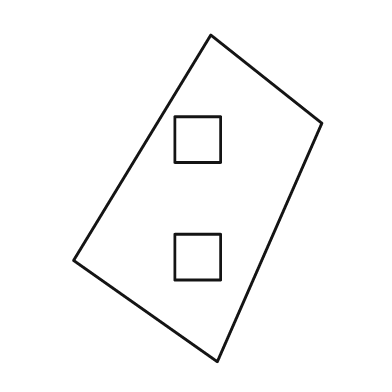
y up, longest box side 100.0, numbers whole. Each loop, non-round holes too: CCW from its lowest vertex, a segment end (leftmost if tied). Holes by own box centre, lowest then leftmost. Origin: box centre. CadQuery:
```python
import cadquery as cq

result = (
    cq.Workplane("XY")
    .moveTo(6.0, -50.0)
    .lineTo(38.0, 23.0)
    .lineTo(4.0, 50.0)
    .lineTo(-38.0, -19.0)
    .close()
    .moveTo(-7.0, -25.0)
    .lineTo(7.0, -25.0)
    .lineTo(7.0, -11.0)
    .lineTo(-7.0, -11.0)
    .close()
    .moveTo(-7.0, 11.0)
    .lineTo(7.0, 11.0)
    .lineTo(7.0, 25.0)
    .lineTo(-7.0, 25.0)
    .close()
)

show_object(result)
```